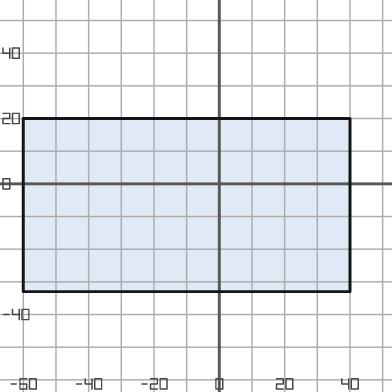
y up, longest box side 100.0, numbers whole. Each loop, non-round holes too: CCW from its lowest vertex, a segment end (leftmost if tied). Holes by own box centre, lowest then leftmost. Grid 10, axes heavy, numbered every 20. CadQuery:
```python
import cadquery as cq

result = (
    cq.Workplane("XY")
    .moveTo(-60.0, -33.0)
    .lineTo(40.0, -33.0)
    .lineTo(40.0, 20.0)
    .lineTo(-60.0, 20.0)
    .close()
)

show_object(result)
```